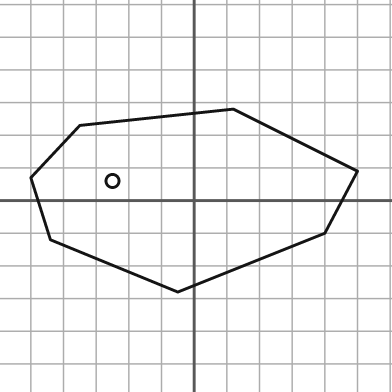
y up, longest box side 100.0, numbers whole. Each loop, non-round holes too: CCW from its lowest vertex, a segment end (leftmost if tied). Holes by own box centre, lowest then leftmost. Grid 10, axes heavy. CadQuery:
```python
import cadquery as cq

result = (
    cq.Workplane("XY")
    .moveTo(-5.0, -28.0)
    .lineTo(40.0, -10.0)
    .lineTo(50.0, 9.0)
    .lineTo(12.0, 28.0)
    .lineTo(-35.0, 23.0)
    .lineTo(-50.0, 7.0)
    .lineTo(-44.0, -12.0)
    .close()
    .moveTo(-25.0, 6.0)
    .circle(2.0)
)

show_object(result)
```